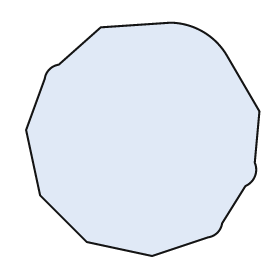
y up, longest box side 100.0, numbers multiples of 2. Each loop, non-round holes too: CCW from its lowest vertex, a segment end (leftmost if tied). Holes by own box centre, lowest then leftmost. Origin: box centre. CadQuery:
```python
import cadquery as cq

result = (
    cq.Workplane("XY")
    .moveTo(4.0, -50.0)
    .lineTo(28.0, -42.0)
    .threePointArc((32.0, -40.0), (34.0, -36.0))
    .lineTo(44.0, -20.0)
    .threePointArc((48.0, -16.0), (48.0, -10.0))
    .lineTo(50.0, 12.0)
    .lineTo(36.0, 36.0)
    .threePointArc((26.0, 46.0), (12.0, 50.0))
    .lineTo(-18.0, 48.0)
    .lineTo(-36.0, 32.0)
    .threePointArc((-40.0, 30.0), (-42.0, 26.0))
    .lineTo(-50.0, 4.0)
    .lineTo(-44.0, -24.0)
    .lineTo(-24.0, -44.0)
    .close()
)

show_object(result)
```